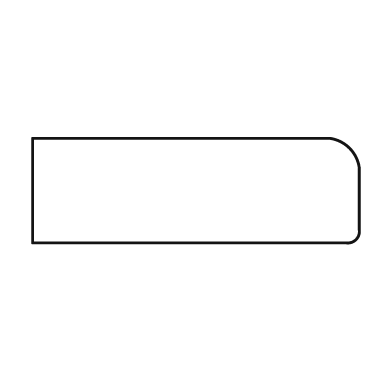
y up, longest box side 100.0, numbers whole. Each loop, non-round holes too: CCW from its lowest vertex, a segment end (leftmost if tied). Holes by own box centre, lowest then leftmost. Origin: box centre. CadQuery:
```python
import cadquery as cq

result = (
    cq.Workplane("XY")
    .moveTo(-50.0, -16.0)
    .lineTo(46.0, -16.0)
    .threePointArc((49.0, -15.0), (50.0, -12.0))
    .lineTo(50.0, 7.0)
    .threePointArc((47.0, 13.0), (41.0, 16.0))
    .lineTo(-50.0, 16.0)
    .close()
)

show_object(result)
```